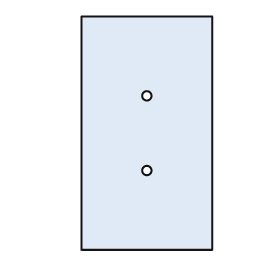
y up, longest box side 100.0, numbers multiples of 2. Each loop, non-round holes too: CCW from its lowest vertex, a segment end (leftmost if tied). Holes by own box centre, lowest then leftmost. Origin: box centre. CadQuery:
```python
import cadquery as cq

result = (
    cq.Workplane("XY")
    .moveTo(-28.0, -50.0)
    .lineTo(28.0, -50.0)
    .lineTo(28.0, 50.0)
    .lineTo(-28.0, 50.0)
    .close()
    .moveTo(0.0, -16.0)
    .circle(2.0)
    .moveTo(0.0, 16.0)
    .circle(2.0)
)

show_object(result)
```